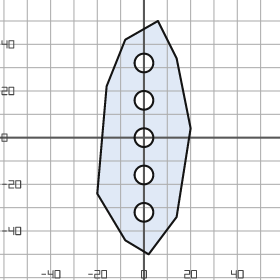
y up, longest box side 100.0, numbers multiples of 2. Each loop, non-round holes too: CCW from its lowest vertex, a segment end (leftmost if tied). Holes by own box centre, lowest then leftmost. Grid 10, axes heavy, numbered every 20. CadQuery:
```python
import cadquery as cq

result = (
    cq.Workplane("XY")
    .moveTo(2.0, -50.0)
    .lineTo(14.0, -34.0)
    .lineTo(20.0, 4.0)
    .lineTo(14.0, 34.0)
    .lineTo(6.0, 50.0)
    .lineTo(-8.0, 42.0)
    .lineTo(-16.0, 22.0)
    .lineTo(-20.0, -24.0)
    .lineTo(-8.0, -44.0)
    .close()
    .moveTo(0.0, -32.0)
    .circle(4.0)
    .moveTo(0.0, -16.0)
    .circle(4.0)
    .moveTo(0.0, 0.0)
    .circle(4.0)
    .moveTo(0.0, 16.0)
    .circle(4.0)
    .moveTo(0.0, 32.0)
    .circle(4.0)
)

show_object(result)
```